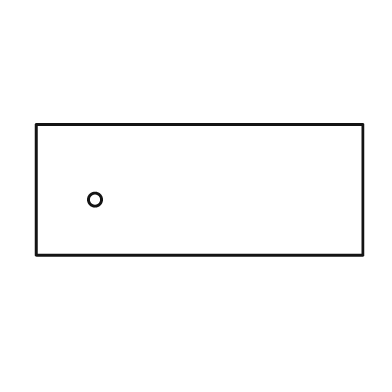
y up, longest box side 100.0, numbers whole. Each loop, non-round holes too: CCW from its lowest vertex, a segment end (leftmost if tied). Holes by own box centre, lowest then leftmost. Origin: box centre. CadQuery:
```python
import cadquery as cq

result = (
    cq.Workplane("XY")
    .moveTo(-50.0, -20.0)
    .lineTo(50.0, -20.0)
    .lineTo(50.0, 20.0)
    .lineTo(-50.0, 20.0)
    .close()
    .moveTo(-32.0, -3.0)
    .circle(2.0)
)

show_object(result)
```